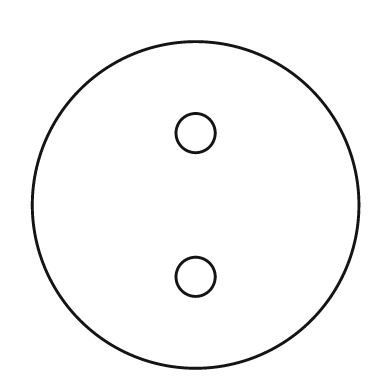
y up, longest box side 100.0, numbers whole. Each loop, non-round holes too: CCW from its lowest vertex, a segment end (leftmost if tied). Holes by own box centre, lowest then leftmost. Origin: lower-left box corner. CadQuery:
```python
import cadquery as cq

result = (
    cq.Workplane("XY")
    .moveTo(50.0, 50.0)
    .circle(50.0)
    .moveTo(50.0, 28.0)
    .circle(6.0)
    .moveTo(50.0, 72.0)
    .circle(6.0)
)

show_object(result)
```